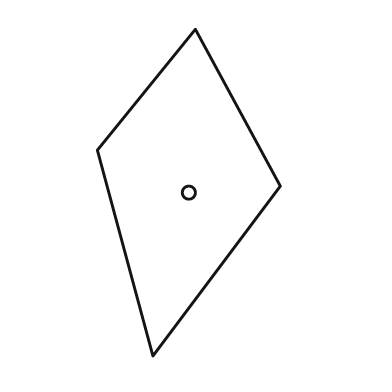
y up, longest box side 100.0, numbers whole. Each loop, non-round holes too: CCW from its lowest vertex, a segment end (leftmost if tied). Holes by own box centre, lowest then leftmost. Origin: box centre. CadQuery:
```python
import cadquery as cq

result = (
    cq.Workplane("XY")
    .moveTo(-11.0, -50.0)
    .lineTo(28.0, 2.0)
    .lineTo(2.0, 50.0)
    .lineTo(-28.0, 13.0)
    .close()
    .moveTo(0.0, 0.0)
    .circle(2.0)
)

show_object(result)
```